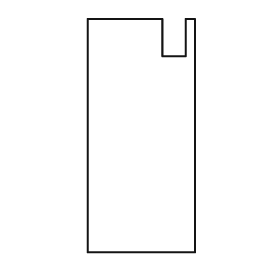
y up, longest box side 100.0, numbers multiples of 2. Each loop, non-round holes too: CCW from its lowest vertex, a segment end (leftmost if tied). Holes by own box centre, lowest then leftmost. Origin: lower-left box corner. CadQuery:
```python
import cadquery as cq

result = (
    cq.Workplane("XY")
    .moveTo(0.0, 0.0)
    .lineTo(46.0, 0.0)
    .lineTo(46.0, 100.0)
    .lineTo(42.0, 100.0)
    .lineTo(42.0, 84.0)
    .lineTo(32.0, 84.0)
    .lineTo(32.0, 100.0)
    .lineTo(0.0, 100.0)
    .close()
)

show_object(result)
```